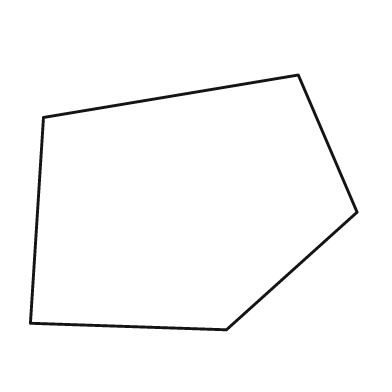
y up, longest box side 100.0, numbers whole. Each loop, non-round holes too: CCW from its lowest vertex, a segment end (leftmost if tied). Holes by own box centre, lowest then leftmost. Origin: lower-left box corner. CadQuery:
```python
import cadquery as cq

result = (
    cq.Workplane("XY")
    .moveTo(60.0, 0.0)
    .lineTo(100.0, 36.0)
    .lineTo(82.0, 78.0)
    .lineTo(4.0, 65.0)
    .lineTo(0.0, 2.0)
    .close()
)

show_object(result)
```